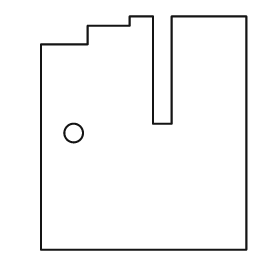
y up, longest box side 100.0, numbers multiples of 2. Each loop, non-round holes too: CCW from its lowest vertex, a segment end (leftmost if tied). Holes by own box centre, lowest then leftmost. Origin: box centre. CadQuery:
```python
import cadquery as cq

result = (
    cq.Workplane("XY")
    .moveTo(-44.0, -50.0)
    .lineTo(44.0, -50.0)
    .lineTo(44.0, 50.0)
    .lineTo(12.0, 50.0)
    .lineTo(12.0, 4.0)
    .lineTo(4.0, 4.0)
    .lineTo(4.0, 50.0)
    .lineTo(-6.0, 50.0)
    .lineTo(-6.0, 46.0)
    .lineTo(-24.0, 46.0)
    .lineTo(-24.0, 38.0)
    .lineTo(-44.0, 38.0)
    .close()
    .moveTo(-30.0, 0.0)
    .circle(4.0)
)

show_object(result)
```